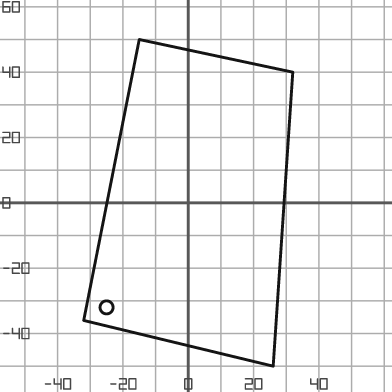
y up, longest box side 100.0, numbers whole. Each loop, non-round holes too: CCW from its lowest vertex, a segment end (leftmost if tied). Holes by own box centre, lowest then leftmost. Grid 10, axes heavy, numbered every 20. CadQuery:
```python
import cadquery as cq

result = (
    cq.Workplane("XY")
    .moveTo(26.0, -50.0)
    .lineTo(32.0, 40.0)
    .lineTo(-15.0, 50.0)
    .lineTo(-32.0, -36.0)
    .close()
    .moveTo(-25.0, -32.0)
    .circle(2.0)
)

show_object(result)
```